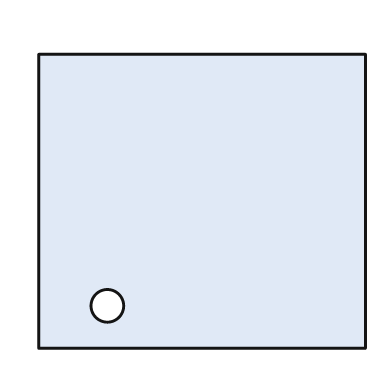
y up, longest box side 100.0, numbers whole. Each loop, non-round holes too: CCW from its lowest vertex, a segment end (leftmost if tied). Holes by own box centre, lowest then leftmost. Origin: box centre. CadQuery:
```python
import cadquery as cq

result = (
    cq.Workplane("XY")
    .moveTo(-50.0, -45.0)
    .lineTo(50.0, -45.0)
    .lineTo(50.0, 45.0)
    .lineTo(-50.0, 45.0)
    .close()
    .moveTo(-29.0, -32.0)
    .circle(5.0)
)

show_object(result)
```